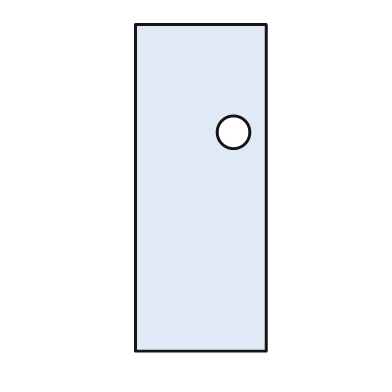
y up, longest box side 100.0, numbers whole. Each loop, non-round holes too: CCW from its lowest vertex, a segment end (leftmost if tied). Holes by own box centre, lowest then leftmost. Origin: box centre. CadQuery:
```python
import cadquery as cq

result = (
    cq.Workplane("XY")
    .moveTo(-20.0, -50.0)
    .lineTo(20.0, -50.0)
    .lineTo(20.0, 50.0)
    .lineTo(-20.0, 50.0)
    .close()
    .moveTo(10.0, 17.0)
    .circle(5.0)
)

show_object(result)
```